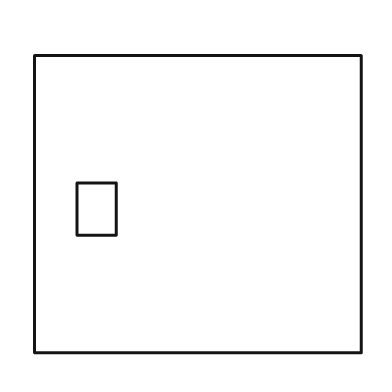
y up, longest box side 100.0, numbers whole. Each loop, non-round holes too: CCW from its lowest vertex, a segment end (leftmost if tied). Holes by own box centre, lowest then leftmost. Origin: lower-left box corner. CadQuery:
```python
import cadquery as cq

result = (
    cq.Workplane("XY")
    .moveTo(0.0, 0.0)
    .lineTo(100.0, 0.0)
    .lineTo(100.0, 91.0)
    .lineTo(0.0, 91.0)
    .close()
    .moveTo(13.0, 36.0)
    .lineTo(25.0, 36.0)
    .lineTo(25.0, 52.0)
    .lineTo(13.0, 52.0)
    .close()
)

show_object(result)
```